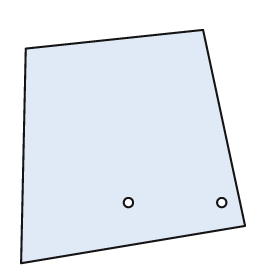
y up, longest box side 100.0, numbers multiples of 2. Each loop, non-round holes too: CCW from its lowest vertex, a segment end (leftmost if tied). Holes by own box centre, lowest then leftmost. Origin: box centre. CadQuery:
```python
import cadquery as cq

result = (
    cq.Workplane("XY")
    .moveTo(-48.0, -50.0)
    .lineTo(48.0, -34.0)
    .lineTo(30.0, 50.0)
    .lineTo(-46.0, 42.0)
    .close()
    .moveTo(-2.0, -24.0)
    .circle(2.0)
    .moveTo(38.0, -24.0)
    .circle(2.0)
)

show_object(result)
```